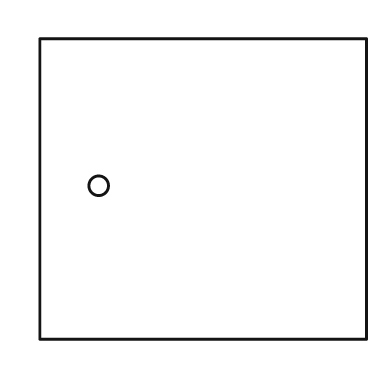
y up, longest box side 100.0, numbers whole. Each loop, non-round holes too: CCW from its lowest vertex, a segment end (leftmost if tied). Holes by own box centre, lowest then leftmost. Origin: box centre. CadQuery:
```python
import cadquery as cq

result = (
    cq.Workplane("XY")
    .moveTo(-50.0, -46.0)
    .lineTo(50.0, -46.0)
    .lineTo(50.0, 46.0)
    .lineTo(-50.0, 46.0)
    .close()
    .moveTo(-32.0, 1.0)
    .circle(3.0)
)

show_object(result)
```